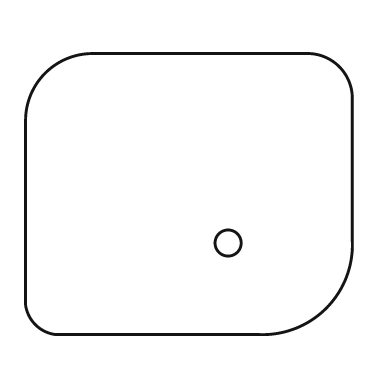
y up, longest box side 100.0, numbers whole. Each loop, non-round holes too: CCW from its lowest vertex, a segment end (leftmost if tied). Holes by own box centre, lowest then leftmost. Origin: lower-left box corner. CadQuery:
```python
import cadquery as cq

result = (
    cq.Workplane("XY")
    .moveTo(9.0, 0.0)
    .lineTo(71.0, 0.0)
    .threePointArc((92.0, 8.0), (100.0, 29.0))
    .lineTo(100.0, 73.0)
    .threePointArc((96.0, 82.0), (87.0, 86.0))
    .lineTo(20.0, 86.0)
    .threePointArc((6.0, 80.0), (0.0, 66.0))
    .lineTo(0.0, 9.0)
    .threePointArc((3.0, 3.0), (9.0, 0.0))
    .close()
    .moveTo(62.0, 28.0)
    .circle(4.0)
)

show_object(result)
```